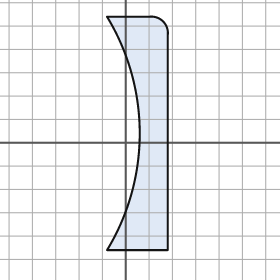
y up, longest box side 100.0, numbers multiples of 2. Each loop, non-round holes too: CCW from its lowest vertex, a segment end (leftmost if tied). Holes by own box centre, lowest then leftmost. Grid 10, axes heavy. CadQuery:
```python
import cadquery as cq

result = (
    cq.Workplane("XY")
    .moveTo(-8.0, -46.0)
    .lineTo(18.0, -46.0)
    .lineTo(18.0, 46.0)
    .threePointArc((16.0, 52.0), (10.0, 54.0))
    .lineTo(-8.0, 54.0)
    .threePointArc((6.0, 4.0), (-8.0, -46.0))
    .close()
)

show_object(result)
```